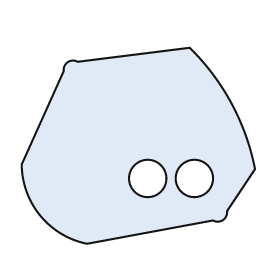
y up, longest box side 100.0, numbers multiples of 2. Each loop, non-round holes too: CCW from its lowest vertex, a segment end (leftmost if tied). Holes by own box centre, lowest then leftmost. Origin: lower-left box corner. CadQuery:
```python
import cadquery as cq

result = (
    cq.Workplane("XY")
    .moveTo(28.0, 0.0)
    .lineTo(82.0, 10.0)
    .threePointArc((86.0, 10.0), (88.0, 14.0))
    .lineTo(100.0, 32.0)
    .threePointArc((90.0, 60.0), (72.0, 84.0))
    .lineTo(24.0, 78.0)
    .threePointArc((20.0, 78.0), (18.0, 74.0))
    .lineTo(0.0, 34.0)
    .threePointArc((8.0, 12.0), (28.0, 0.0))
    .close()
    .moveTo(54.0, 28.0)
    .circle(8.0)
    .moveTo(74.0, 28.0)
    .circle(8.0)
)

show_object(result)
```